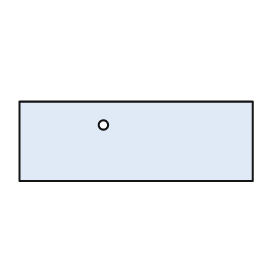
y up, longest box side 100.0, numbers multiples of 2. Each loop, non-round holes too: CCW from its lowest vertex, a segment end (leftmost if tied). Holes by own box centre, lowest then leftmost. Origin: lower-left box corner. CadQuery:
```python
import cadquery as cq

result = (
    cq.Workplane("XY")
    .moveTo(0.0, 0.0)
    .lineTo(100.0, 0.0)
    .lineTo(100.0, 34.0)
    .lineTo(0.0, 34.0)
    .close()
    .moveTo(36.0, 24.0)
    .circle(2.0)
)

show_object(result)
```